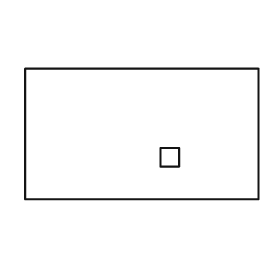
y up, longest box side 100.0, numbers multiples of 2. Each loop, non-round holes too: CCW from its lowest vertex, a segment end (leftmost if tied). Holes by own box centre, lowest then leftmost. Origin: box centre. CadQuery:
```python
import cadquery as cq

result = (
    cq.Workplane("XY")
    .moveTo(-50.0, -28.0)
    .lineTo(50.0, -28.0)
    .lineTo(50.0, 28.0)
    .lineTo(-50.0, 28.0)
    .close()
    .moveTo(8.0, -14.0)
    .lineTo(16.0, -14.0)
    .lineTo(16.0, -6.0)
    .lineTo(8.0, -6.0)
    .close()
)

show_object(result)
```